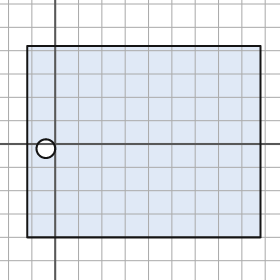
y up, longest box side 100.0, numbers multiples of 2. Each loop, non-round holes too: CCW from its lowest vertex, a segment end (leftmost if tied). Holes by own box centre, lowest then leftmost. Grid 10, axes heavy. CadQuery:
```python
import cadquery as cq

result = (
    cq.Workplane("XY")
    .moveTo(-12.0, -40.0)
    .lineTo(88.0, -40.0)
    .lineTo(88.0, 42.0)
    .lineTo(-12.0, 42.0)
    .close()
    .moveTo(-4.0, -2.0)
    .circle(4.0)
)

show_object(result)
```